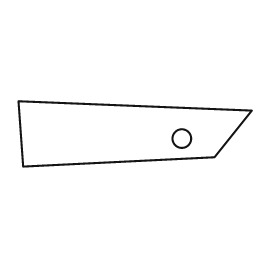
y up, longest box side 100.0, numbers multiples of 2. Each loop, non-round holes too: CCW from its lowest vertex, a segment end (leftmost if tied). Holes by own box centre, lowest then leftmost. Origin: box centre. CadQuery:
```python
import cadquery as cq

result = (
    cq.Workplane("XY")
    .moveTo(-48.0, -14.0)
    .lineTo(34.0, -10.0)
    .lineTo(50.0, 10.0)
    .lineTo(-50.0, 14.0)
    .close()
    .moveTo(20.0, -2.0)
    .circle(4.0)
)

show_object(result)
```